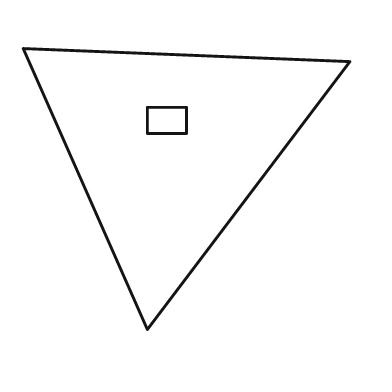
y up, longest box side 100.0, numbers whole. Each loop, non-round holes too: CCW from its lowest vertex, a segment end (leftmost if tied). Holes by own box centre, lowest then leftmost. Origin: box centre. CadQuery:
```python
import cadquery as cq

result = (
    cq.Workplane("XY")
    .moveTo(-12.0, -43.0)
    .lineTo(50.0, 39.0)
    .lineTo(-50.0, 43.0)
    .close()
    .moveTo(-12.0, 17.0)
    .lineTo(0.0, 17.0)
    .lineTo(0.0, 25.0)
    .lineTo(-12.0, 25.0)
    .close()
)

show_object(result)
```